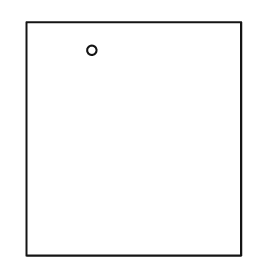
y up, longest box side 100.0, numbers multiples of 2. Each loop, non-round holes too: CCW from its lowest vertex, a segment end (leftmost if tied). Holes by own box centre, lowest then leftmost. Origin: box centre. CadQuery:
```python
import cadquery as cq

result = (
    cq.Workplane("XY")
    .moveTo(-46.0, -50.0)
    .lineTo(46.0, -50.0)
    .lineTo(46.0, 50.0)
    .lineTo(-46.0, 50.0)
    .close()
    .moveTo(-18.0, 38.0)
    .circle(2.0)
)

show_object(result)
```